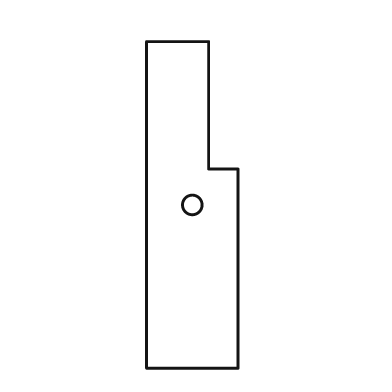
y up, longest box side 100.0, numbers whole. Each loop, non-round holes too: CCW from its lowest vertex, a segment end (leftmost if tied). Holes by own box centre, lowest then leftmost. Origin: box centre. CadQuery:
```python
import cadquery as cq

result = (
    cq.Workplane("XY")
    .moveTo(-14.0, -50.0)
    .lineTo(14.0, -50.0)
    .lineTo(14.0, 11.0)
    .lineTo(5.0, 11.0)
    .lineTo(5.0, 50.0)
    .lineTo(-14.0, 50.0)
    .close()
    .moveTo(0.0, 0.0)
    .circle(3.0)
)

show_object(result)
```